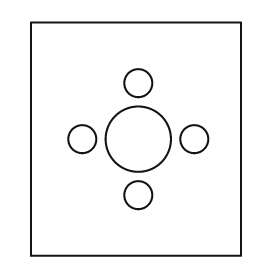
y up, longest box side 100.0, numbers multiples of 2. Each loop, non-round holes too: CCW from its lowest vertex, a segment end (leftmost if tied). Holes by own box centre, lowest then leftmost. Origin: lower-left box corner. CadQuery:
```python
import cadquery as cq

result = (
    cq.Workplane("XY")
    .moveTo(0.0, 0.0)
    .lineTo(90.0, 0.0)
    .lineTo(90.0, 100.0)
    .lineTo(0.0, 100.0)
    .close()
    .moveTo(46.0, 26.0)
    .circle(6.0)
    .moveTo(22.0, 50.0)
    .circle(6.0)
    .moveTo(46.0, 50.0)
    .circle(14.0)
    .moveTo(70.0, 50.0)
    .circle(6.0)
    .moveTo(46.0, 74.0)
    .circle(6.0)
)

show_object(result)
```